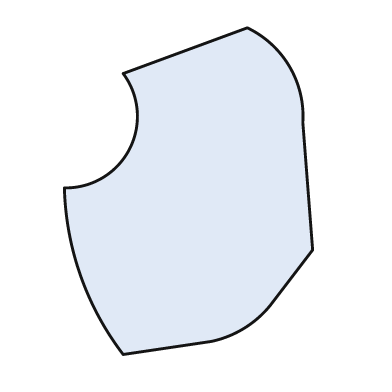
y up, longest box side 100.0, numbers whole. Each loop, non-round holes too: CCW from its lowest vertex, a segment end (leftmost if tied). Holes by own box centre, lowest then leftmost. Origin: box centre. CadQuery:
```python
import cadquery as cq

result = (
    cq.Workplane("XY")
    .moveTo(-20.0, -50.0)
    .lineTo(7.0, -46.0)
    .threePointArc((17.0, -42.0), (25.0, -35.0))
    .lineTo(38.0, -18.0)
    .lineTo(35.0, 21.0)
    .threePointArc((31.0, 38.0), (18.0, 50.0))
    .lineTo(-20.0, 36.0)
    .threePointArc((-18.0, 13.0), (-38.0, 1.0))
    .threePointArc((-33.0, -26.0), (-20.0, -50.0))
    .close()
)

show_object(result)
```